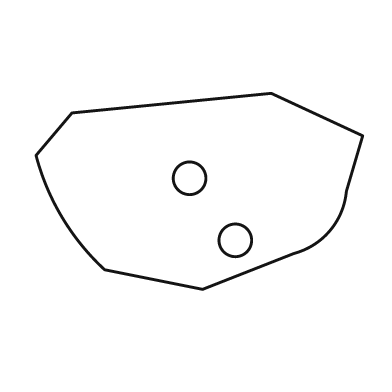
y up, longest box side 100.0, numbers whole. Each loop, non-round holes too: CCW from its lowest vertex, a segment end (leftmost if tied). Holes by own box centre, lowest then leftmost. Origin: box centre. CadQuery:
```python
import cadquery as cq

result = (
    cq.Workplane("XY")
    .moveTo(1.0, -30.0)
    .lineTo(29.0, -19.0)
    .threePointArc((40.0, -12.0), (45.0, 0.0))
    .lineTo(50.0, 17.0)
    .lineTo(22.0, 30.0)
    .lineTo(-39.0, 24.0)
    .lineTo(-50.0, 11.0)
    .threePointArc((-42.0, -8.0), (-29.0, -24.0))
    .close()
    .moveTo(11.0, -15.0)
    .circle(5.0)
    .moveTo(-3.0, 4.0)
    .circle(5.0)
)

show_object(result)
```